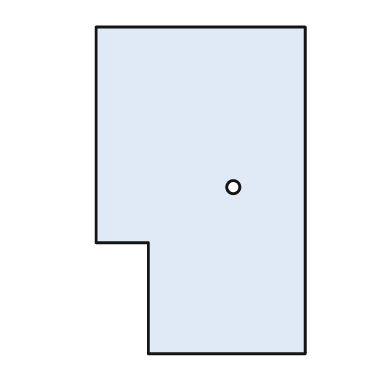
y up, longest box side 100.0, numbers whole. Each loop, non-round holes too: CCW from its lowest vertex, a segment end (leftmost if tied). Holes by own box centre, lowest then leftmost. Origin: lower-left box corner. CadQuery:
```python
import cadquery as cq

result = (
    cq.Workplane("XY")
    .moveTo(16.0, 0.0)
    .lineTo(64.0, 0.0)
    .lineTo(64.0, 100.0)
    .lineTo(0.0, 100.0)
    .lineTo(0.0, 34.0)
    .lineTo(16.0, 34.0)
    .close()
    .moveTo(42.0, 51.0)
    .circle(2.0)
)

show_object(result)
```